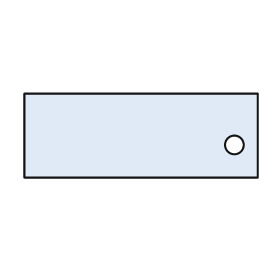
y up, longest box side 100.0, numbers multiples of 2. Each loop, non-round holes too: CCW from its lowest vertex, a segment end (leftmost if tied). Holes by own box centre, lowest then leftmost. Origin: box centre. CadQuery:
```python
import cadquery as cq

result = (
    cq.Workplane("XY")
    .moveTo(-50.0, -18.0)
    .lineTo(50.0, -18.0)
    .lineTo(50.0, 18.0)
    .lineTo(-50.0, 18.0)
    .close()
    .moveTo(40.0, -4.0)
    .circle(4.0)
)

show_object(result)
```